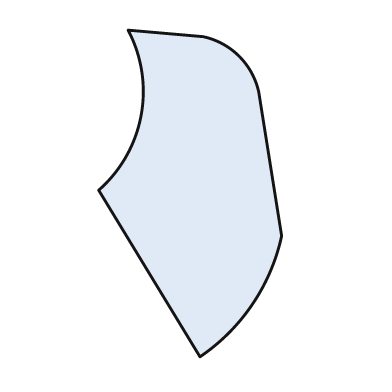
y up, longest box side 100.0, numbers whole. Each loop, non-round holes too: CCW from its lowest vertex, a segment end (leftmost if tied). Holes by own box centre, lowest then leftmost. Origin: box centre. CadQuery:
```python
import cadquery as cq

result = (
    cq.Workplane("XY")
    .moveTo(3.0, -50.0)
    .threePointArc((19.0, -34.0), (28.0, -13.0))
    .lineTo(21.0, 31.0)
    .threePointArc((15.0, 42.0), (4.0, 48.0))
    .lineTo(-19.0, 50.0)
    .threePointArc((-15.0, 24.0), (-28.0, 1.0))
    .close()
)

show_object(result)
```